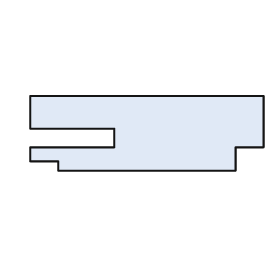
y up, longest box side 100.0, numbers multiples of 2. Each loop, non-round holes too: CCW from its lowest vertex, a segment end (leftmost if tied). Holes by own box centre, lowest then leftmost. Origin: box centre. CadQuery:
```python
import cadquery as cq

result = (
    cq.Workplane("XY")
    .moveTo(-38.0, -16.0)
    .lineTo(38.0, -16.0)
    .lineTo(38.0, -6.0)
    .lineTo(50.0, -6.0)
    .lineTo(50.0, 16.0)
    .lineTo(-50.0, 16.0)
    .lineTo(-50.0, 2.0)
    .lineTo(-14.0, 2.0)
    .lineTo(-14.0, -6.0)
    .lineTo(-50.0, -6.0)
    .lineTo(-50.0, -12.0)
    .lineTo(-38.0, -12.0)
    .close()
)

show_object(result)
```